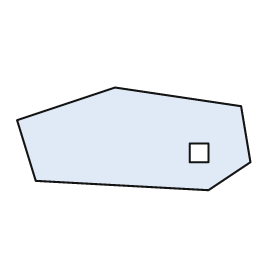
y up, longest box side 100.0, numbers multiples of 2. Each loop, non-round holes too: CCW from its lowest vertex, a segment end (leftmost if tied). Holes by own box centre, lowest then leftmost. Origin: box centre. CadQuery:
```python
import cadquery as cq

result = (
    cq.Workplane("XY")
    .moveTo(32.0, -22.0)
    .lineTo(50.0, -10.0)
    .lineTo(46.0, 14.0)
    .lineTo(-8.0, 22.0)
    .lineTo(-50.0, 8.0)
    .lineTo(-42.0, -18.0)
    .close()
    .moveTo(24.0, -10.0)
    .lineTo(32.0, -10.0)
    .lineTo(32.0, -2.0)
    .lineTo(24.0, -2.0)
    .close()
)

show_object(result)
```